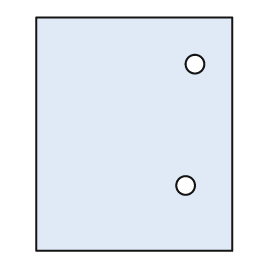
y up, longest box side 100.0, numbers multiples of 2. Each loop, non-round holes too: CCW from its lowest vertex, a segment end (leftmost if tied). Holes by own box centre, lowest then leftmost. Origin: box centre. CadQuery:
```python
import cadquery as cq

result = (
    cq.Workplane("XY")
    .moveTo(-42.0, -50.0)
    .lineTo(42.0, -50.0)
    .lineTo(42.0, 50.0)
    .lineTo(-42.0, 50.0)
    .close()
    .moveTo(22.0, -22.0)
    .circle(4.0)
    .moveTo(26.0, 30.0)
    .circle(4.0)
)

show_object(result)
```